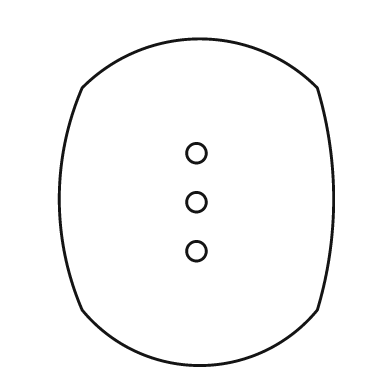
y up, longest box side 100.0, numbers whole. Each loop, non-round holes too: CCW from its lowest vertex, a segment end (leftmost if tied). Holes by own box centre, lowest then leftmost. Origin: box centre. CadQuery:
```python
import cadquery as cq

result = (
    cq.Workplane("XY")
    .moveTo(-35.0, -33.0)
    .threePointArc((1.0, -50.0), (37.0, -33.0))
    .threePointArc((42.0, 1.0), (37.0, 35.0))
    .threePointArc((1.0, 50.0), (-35.0, 35.0))
    .threePointArc((-42.0, 1.0), (-35.0, -33.0))
    .close()
    .moveTo(0.0, -15.0)
    .circle(3.0)
    .moveTo(0.0, 0.0)
    .circle(3.0)
    .moveTo(0.0, 15.0)
    .circle(3.0)
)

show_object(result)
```